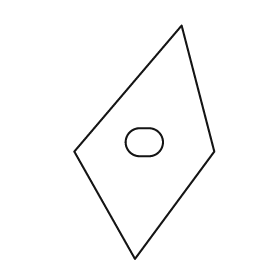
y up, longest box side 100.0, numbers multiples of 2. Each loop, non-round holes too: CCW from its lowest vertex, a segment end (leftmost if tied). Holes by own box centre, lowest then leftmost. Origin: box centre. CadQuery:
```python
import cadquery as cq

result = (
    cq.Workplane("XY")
    .moveTo(-4.0, -50.0)
    .lineTo(30.0, -4.0)
    .lineTo(16.0, 50.0)
    .lineTo(-30.0, -4.0)
    .close()
    .moveTo(-2.0, -6.0)
    .lineTo(2.0, -6.0)
    .threePointArc((8.0, 0.0), (2.0, 6.0))
    .lineTo(-2.0, 6.0)
    .threePointArc((-8.0, 0.0), (-2.0, -6.0))
    .close()
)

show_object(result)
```